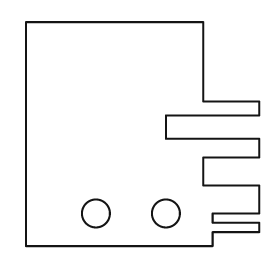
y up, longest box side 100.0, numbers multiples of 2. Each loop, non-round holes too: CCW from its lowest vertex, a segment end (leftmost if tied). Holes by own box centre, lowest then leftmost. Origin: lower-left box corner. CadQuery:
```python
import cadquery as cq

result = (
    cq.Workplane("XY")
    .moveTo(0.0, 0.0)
    .lineTo(80.0, 0.0)
    .lineTo(80.0, 6.0)
    .lineTo(100.0, 6.0)
    .lineTo(100.0, 10.0)
    .lineTo(80.0, 10.0)
    .lineTo(80.0, 14.0)
    .lineTo(100.0, 14.0)
    .lineTo(100.0, 26.0)
    .lineTo(76.0, 26.0)
    .lineTo(76.0, 38.0)
    .lineTo(100.0, 38.0)
    .lineTo(100.0, 46.0)
    .lineTo(60.0, 46.0)
    .lineTo(60.0, 56.0)
    .lineTo(100.0, 56.0)
    .lineTo(100.0, 62.0)
    .lineTo(76.0, 62.0)
    .lineTo(76.0, 96.0)
    .lineTo(0.0, 96.0)
    .close()
    .moveTo(30.0, 14.0)
    .circle(6.0)
    .moveTo(60.0, 14.0)
    .circle(6.0)
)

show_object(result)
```